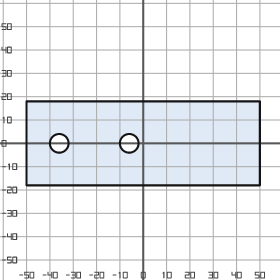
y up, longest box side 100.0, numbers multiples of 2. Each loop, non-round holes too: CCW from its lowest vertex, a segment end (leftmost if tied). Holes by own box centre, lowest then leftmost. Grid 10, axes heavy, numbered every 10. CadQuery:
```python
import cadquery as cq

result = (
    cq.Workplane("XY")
    .moveTo(-50.0, -18.0)
    .lineTo(50.0, -18.0)
    .lineTo(50.0, 18.0)
    .lineTo(-50.0, 18.0)
    .close()
    .moveTo(-36.0, 0.0)
    .circle(4.0)
    .moveTo(-6.0, 0.0)
    .circle(4.0)
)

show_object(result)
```